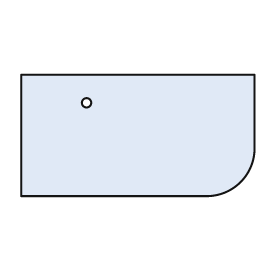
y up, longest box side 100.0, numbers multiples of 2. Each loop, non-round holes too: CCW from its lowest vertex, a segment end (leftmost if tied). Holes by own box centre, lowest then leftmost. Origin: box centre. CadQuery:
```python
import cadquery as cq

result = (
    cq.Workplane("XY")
    .moveTo(-50.0, -26.0)
    .lineTo(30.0, -26.0)
    .threePointArc((44.0, -20.0), (50.0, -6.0))
    .lineTo(50.0, 26.0)
    .lineTo(-50.0, 26.0)
    .close()
    .moveTo(-22.0, 14.0)
    .circle(2.0)
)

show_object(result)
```